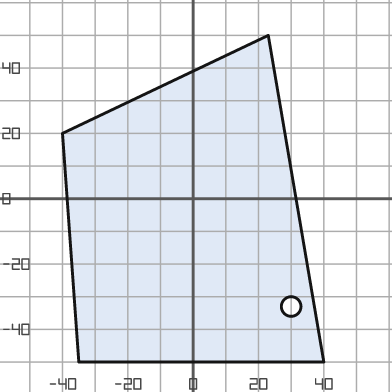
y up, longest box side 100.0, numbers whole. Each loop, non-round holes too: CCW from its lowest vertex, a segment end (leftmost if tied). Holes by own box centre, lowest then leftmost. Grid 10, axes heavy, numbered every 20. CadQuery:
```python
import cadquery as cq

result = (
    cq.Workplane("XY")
    .moveTo(-35.0, -50.0)
    .lineTo(40.0, -50.0)
    .lineTo(23.0, 50.0)
    .lineTo(-40.0, 20.0)
    .close()
    .moveTo(30.0, -33.0)
    .circle(3.0)
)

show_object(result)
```